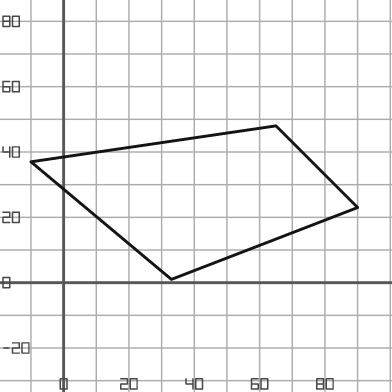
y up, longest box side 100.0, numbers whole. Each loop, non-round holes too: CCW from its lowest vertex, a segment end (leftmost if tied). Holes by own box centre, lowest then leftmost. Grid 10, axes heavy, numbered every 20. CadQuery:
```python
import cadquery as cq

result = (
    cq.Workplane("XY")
    .moveTo(33.0, 1.0)
    .lineTo(90.0, 23.0)
    .lineTo(65.0, 48.0)
    .lineTo(-10.0, 37.0)
    .close()
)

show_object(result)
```